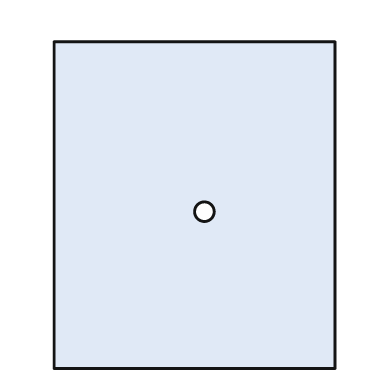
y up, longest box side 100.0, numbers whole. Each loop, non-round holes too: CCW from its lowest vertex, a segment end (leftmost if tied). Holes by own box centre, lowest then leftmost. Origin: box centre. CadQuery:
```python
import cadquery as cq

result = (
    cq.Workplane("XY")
    .moveTo(-43.0, -50.0)
    .lineTo(43.0, -50.0)
    .lineTo(43.0, 50.0)
    .lineTo(-43.0, 50.0)
    .close()
    .moveTo(3.0, -2.0)
    .circle(3.0)
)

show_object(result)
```